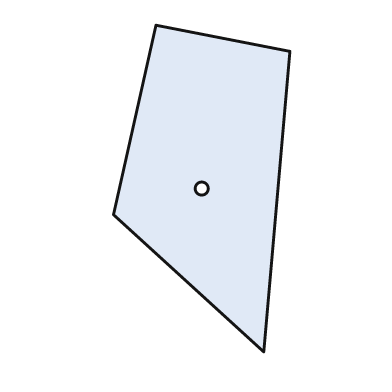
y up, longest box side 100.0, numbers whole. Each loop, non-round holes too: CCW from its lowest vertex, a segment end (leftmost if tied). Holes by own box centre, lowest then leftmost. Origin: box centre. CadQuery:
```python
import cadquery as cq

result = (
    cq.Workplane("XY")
    .moveTo(19.0, -50.0)
    .lineTo(27.0, 42.0)
    .lineTo(-14.0, 50.0)
    .lineTo(-27.0, -8.0)
    .close()
    .moveTo(0.0, 0.0)
    .circle(2.0)
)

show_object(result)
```